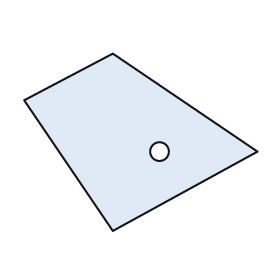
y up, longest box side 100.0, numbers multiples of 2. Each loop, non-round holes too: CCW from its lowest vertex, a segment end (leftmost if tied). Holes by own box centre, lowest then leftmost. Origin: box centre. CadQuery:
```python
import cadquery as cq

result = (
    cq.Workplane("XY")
    .moveTo(-12.0, -38.0)
    .lineTo(50.0, -4.0)
    .lineTo(-12.0, 38.0)
    .lineTo(-50.0, 18.0)
    .close()
    .moveTo(8.0, -4.0)
    .circle(4.0)
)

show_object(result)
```